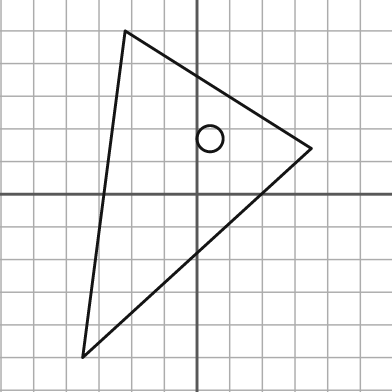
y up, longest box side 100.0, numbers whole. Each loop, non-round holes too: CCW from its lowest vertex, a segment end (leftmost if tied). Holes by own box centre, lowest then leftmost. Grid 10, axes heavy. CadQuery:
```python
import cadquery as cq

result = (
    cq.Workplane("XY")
    .moveTo(-35.0, -50.0)
    .lineTo(35.0, 14.0)
    .lineTo(-22.0, 50.0)
    .close()
    .moveTo(4.0, 17.0)
    .circle(4.0)
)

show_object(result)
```